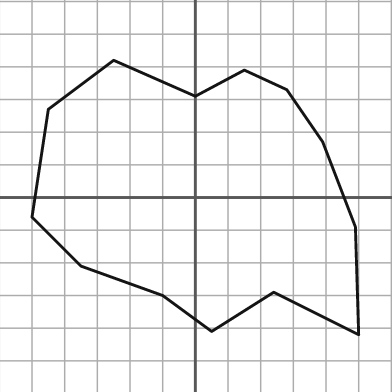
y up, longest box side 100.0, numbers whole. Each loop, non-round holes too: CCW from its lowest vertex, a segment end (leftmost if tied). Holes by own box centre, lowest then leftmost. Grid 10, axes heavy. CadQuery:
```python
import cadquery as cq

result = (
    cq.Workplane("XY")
    .moveTo(50.0, -42.0)
    .lineTo(49.0, -9.0)
    .lineTo(39.0, 17.0)
    .lineTo(28.0, 33.0)
    .lineTo(15.0, 39.0)
    .lineTo(0.0, 31.0)
    .lineTo(-25.0, 42.0)
    .lineTo(-45.0, 27.0)
    .lineTo(-50.0, -6.0)
    .lineTo(-35.0, -21.0)
    .lineTo(-10.0, -30.0)
    .lineTo(5.0, -41.0)
    .lineTo(24.0, -29.0)
    .close()
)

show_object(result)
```